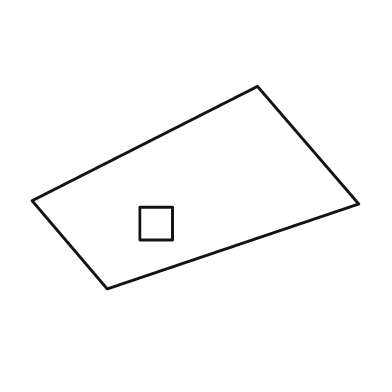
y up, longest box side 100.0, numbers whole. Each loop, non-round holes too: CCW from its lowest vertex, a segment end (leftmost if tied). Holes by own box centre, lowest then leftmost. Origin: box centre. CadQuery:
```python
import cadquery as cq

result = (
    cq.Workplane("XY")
    .moveTo(-27.0, -31.0)
    .lineTo(50.0, -5.0)
    .lineTo(19.0, 31.0)
    .lineTo(-50.0, -4.0)
    .close()
    .moveTo(-17.0, -16.0)
    .lineTo(-7.0, -16.0)
    .lineTo(-7.0, -6.0)
    .lineTo(-17.0, -6.0)
    .close()
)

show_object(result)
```